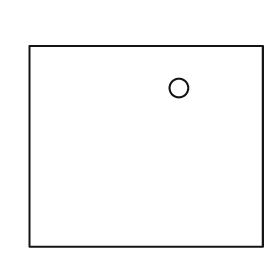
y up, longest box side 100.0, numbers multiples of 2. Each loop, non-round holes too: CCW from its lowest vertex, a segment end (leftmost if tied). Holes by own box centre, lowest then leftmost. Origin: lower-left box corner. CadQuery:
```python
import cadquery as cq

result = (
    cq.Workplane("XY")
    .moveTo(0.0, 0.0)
    .lineTo(100.0, 0.0)
    .lineTo(100.0, 86.0)
    .lineTo(0.0, 86.0)
    .close()
    .moveTo(64.0, 68.0)
    .circle(4.0)
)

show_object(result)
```